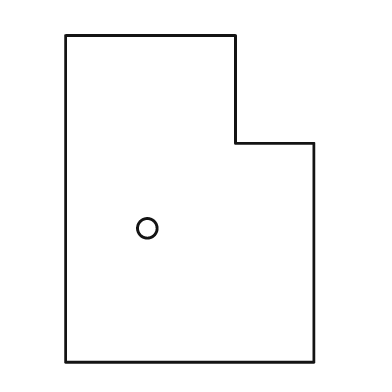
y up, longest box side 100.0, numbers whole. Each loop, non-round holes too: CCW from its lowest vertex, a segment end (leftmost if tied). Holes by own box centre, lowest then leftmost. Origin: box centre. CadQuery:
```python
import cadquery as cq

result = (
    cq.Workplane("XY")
    .moveTo(-38.0, -50.0)
    .lineTo(38.0, -50.0)
    .lineTo(38.0, 17.0)
    .lineTo(14.0, 17.0)
    .lineTo(14.0, 50.0)
    .lineTo(-38.0, 50.0)
    .close()
    .moveTo(-13.0, -9.0)
    .circle(3.0)
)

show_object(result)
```